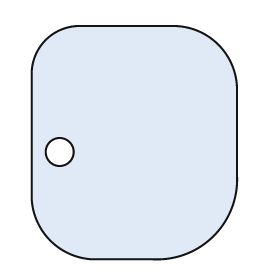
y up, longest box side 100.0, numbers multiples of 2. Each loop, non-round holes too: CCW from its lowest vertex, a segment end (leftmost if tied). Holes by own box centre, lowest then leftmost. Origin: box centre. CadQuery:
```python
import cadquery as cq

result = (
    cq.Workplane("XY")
    .moveTo(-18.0, -50.0)
    .lineTo(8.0, -50.0)
    .threePointArc((34.0, -40.0), (44.0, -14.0))
    .lineTo(44.0, 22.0)
    .threePointArc((36.0, 42.0), (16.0, 50.0))
    .lineTo(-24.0, 50.0)
    .threePointArc((-38.0, 44.0), (-44.0, 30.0))
    .lineTo(-44.0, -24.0)
    .threePointArc((-36.0, -42.0), (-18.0, -50.0))
    .close()
    .moveTo(-32.0, -4.0)
    .circle(6.0)
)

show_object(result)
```